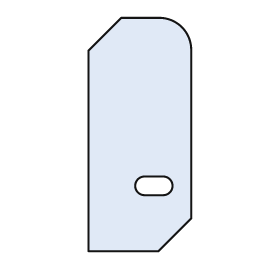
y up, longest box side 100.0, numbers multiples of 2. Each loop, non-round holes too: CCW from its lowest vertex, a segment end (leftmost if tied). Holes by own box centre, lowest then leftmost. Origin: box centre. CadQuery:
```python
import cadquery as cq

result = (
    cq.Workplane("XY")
    .moveTo(-22.0, -50.0)
    .lineTo(8.0, -50.0)
    .lineTo(22.0, -36.0)
    .lineTo(22.0, 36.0)
    .threePointArc((18.0, 46.0), (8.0, 50.0))
    .lineTo(-8.0, 50.0)
    .lineTo(-22.0, 36.0)
    .close()
    .moveTo(2.0, -26.0)
    .lineTo(10.0, -26.0)
    .threePointArc((14.0, -22.0), (10.0, -18.0))
    .lineTo(2.0, -18.0)
    .threePointArc((-2.0, -22.0), (2.0, -26.0))
    .close()
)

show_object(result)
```